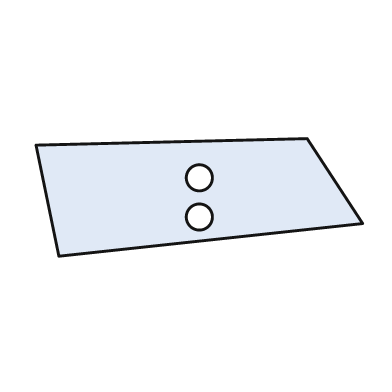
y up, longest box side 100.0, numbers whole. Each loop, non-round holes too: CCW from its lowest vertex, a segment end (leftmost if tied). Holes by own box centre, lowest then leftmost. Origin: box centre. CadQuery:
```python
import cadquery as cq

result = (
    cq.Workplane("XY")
    .moveTo(-43.0, -18.0)
    .lineTo(50.0, -8.0)
    .lineTo(33.0, 18.0)
    .lineTo(-50.0, 16.0)
    .close()
    .moveTo(0.0, -6.0)
    .circle(4.0)
    .moveTo(0.0, 6.0)
    .circle(4.0)
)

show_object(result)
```